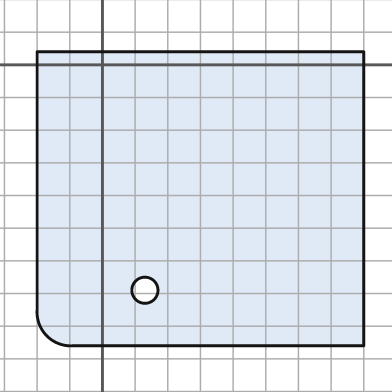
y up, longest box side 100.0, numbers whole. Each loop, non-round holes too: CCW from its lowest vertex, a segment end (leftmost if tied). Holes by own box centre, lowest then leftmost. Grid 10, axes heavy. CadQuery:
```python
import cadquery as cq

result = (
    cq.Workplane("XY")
    .moveTo(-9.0, -86.0)
    .lineTo(80.0, -86.0)
    .lineTo(80.0, 4.0)
    .lineTo(-20.0, 4.0)
    .lineTo(-20.0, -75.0)
    .threePointArc((-17.0, -83.0), (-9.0, -86.0))
    .close()
    .moveTo(13.0, -69.0)
    .circle(4.0)
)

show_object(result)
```